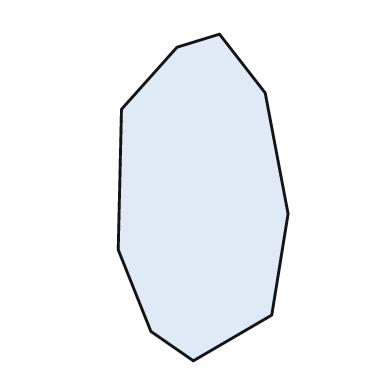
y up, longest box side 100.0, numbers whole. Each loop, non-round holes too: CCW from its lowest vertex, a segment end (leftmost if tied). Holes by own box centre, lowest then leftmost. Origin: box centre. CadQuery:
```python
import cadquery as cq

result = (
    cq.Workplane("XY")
    .moveTo(-3.0, -50.0)
    .lineTo(21.0, -36.0)
    .lineTo(26.0, -5.0)
    .lineTo(19.0, 32.0)
    .lineTo(5.0, 50.0)
    .lineTo(-8.0, 46.0)
    .lineTo(-25.0, 27.0)
    .lineTo(-26.0, -16.0)
    .lineTo(-16.0, -41.0)
    .close()
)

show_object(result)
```